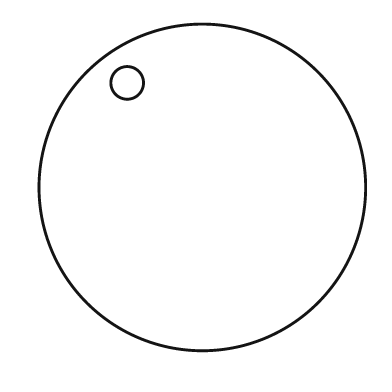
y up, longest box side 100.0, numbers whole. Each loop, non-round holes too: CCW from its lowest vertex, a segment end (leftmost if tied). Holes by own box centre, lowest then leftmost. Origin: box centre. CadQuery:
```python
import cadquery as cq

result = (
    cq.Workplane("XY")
    .moveTo(0.0, 0.0)
    .circle(50.0)
    .moveTo(-23.0, 32.0)
    .circle(5.0)
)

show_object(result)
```